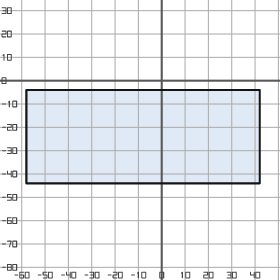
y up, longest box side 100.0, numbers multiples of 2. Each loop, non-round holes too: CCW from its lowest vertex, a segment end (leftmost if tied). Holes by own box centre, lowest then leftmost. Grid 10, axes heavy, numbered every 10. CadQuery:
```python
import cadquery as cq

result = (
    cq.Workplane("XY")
    .moveTo(-58.0, -44.0)
    .lineTo(42.0, -44.0)
    .lineTo(42.0, -4.0)
    .lineTo(-58.0, -4.0)
    .close()
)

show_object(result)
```